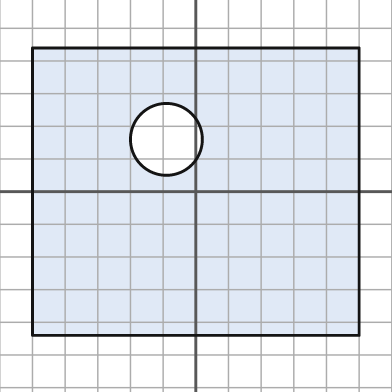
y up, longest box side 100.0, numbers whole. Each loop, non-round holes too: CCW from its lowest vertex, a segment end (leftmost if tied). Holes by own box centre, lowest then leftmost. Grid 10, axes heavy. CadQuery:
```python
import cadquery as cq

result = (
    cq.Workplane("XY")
    .moveTo(-50.0, -44.0)
    .lineTo(50.0, -44.0)
    .lineTo(50.0, 44.0)
    .lineTo(-50.0, 44.0)
    .close()
    .moveTo(-9.0, 16.0)
    .circle(11.0)
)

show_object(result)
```